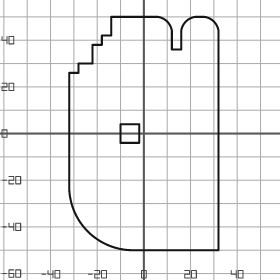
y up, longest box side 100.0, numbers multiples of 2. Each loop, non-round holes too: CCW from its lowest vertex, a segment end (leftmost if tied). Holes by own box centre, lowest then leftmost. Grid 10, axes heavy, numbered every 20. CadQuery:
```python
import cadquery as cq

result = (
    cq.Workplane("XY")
    .moveTo(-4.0, -50.0)
    .lineTo(32.0, -50.0)
    .lineTo(32.0, 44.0)
    .threePointArc((30.0, 48.0), (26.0, 50.0))
    .lineTo(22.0, 50.0)
    .threePointArc((18.0, 48.0), (16.0, 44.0))
    .lineTo(16.0, 36.0)
    .lineTo(12.0, 36.0)
    .lineTo(12.0, 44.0)
    .threePointArc((10.0, 48.0), (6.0, 50.0))
    .lineTo(-14.0, 50.0)
    .lineTo(-14.0, 42.0)
    .lineTo(-18.0, 42.0)
    .lineTo(-18.0, 38.0)
    .lineTo(-22.0, 38.0)
    .lineTo(-22.0, 30.0)
    .lineTo(-28.0, 30.0)
    .lineTo(-28.0, 26.0)
    .lineTo(-32.0, 26.0)
    .lineTo(-32.0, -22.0)
    .threePointArc((-24.0, -42.0), (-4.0, -50.0))
    .close()
    .moveTo(-10.0, -4.0)
    .lineTo(-2.0, -4.0)
    .lineTo(-2.0, 4.0)
    .lineTo(-10.0, 4.0)
    .close()
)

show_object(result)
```